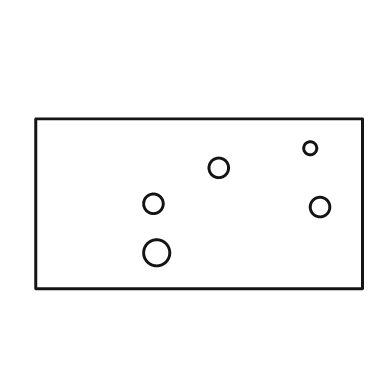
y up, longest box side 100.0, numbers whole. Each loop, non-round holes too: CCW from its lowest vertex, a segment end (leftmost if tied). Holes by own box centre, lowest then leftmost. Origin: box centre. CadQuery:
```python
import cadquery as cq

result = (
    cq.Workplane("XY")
    .moveTo(-50.0, -26.0)
    .lineTo(50.0, -26.0)
    .lineTo(50.0, 26.0)
    .lineTo(-50.0, 26.0)
    .close()
    .moveTo(-13.0, -15.0)
    .circle(4.0)
    .moveTo(37.0, -1.0)
    .circle(3.0)
    .moveTo(-14.0, 0.0)
    .circle(3.0)
    .moveTo(6.0, 11.0)
    .circle(3.0)
    .moveTo(34.0, 17.0)
    .circle(2.0)
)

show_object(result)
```